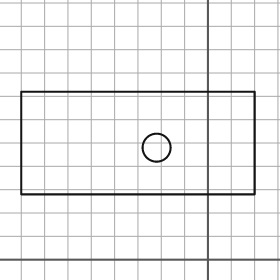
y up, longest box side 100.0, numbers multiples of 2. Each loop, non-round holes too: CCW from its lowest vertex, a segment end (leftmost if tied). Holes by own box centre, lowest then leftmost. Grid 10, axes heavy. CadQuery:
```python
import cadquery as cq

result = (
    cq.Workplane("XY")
    .moveTo(-80.0, 28.0)
    .lineTo(20.0, 28.0)
    .lineTo(20.0, 72.0)
    .lineTo(-80.0, 72.0)
    .close()
    .moveTo(-22.0, 48.0)
    .circle(6.0)
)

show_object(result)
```